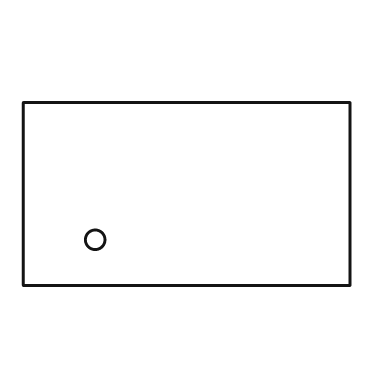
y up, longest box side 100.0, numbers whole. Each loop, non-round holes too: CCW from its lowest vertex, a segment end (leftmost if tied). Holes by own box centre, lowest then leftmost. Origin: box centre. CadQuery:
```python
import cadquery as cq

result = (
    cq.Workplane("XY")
    .moveTo(-50.0, -28.0)
    .lineTo(50.0, -28.0)
    .lineTo(50.0, 28.0)
    .lineTo(-50.0, 28.0)
    .close()
    .moveTo(-28.0, -14.0)
    .circle(3.0)
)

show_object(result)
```